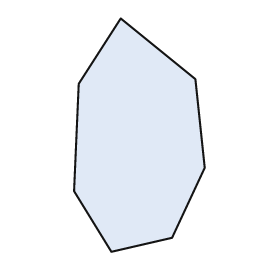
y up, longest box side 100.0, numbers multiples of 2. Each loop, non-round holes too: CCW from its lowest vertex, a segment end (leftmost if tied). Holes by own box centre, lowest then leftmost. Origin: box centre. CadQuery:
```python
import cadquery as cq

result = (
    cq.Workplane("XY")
    .moveTo(-12.0, -50.0)
    .lineTo(14.0, -44.0)
    .lineTo(28.0, -14.0)
    .lineTo(24.0, 24.0)
    .lineTo(-8.0, 50.0)
    .lineTo(-26.0, 22.0)
    .lineTo(-28.0, -24.0)
    .close()
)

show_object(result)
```